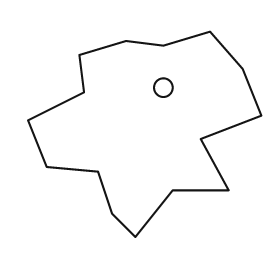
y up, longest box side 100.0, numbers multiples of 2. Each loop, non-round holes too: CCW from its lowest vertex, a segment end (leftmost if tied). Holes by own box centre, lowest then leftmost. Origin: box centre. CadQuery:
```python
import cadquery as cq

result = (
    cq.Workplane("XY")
    .moveTo(-4.0, -44.0)
    .lineTo(12.0, -24.0)
    .lineTo(36.0, -24.0)
    .lineTo(24.0, -2.0)
    .lineTo(50.0, 8.0)
    .lineTo(42.0, 28.0)
    .lineTo(28.0, 44.0)
    .lineTo(8.0, 38.0)
    .lineTo(-8.0, 40.0)
    .lineTo(-28.0, 34.0)
    .lineTo(-26.0, 18.0)
    .lineTo(-50.0, 6.0)
    .lineTo(-42.0, -14.0)
    .lineTo(-20.0, -16.0)
    .lineTo(-14.0, -34.0)
    .close()
    .moveTo(8.0, 20.0)
    .circle(4.0)
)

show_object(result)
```